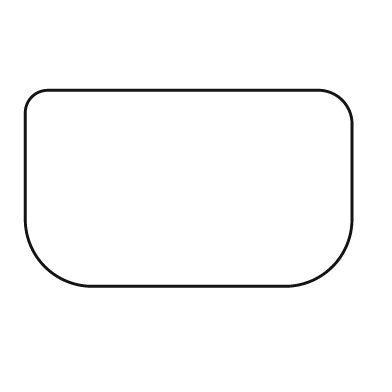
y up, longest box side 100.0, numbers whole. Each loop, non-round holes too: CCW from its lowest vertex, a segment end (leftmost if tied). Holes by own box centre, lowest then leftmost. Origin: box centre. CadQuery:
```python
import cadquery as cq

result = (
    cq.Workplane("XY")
    .moveTo(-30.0, -30.0)
    .lineTo(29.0, -30.0)
    .threePointArc((44.0, -24.0), (50.0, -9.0))
    .lineTo(50.0, 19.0)
    .threePointArc((47.0, 27.0), (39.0, 30.0))
    .lineTo(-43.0, 30.0)
    .threePointArc((-48.0, 28.0), (-50.0, 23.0))
    .lineTo(-50.0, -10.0)
    .threePointArc((-44.0, -24.0), (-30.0, -30.0))
    .close()
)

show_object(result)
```